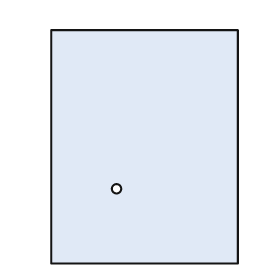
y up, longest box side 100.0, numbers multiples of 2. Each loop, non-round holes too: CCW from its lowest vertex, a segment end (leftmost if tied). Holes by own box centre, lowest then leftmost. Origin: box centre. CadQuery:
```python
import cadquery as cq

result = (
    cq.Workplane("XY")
    .moveTo(-40.0, -50.0)
    .lineTo(40.0, -50.0)
    .lineTo(40.0, 50.0)
    .lineTo(-40.0, 50.0)
    .close()
    .moveTo(-12.0, -18.0)
    .circle(2.0)
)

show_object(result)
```